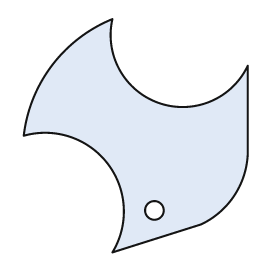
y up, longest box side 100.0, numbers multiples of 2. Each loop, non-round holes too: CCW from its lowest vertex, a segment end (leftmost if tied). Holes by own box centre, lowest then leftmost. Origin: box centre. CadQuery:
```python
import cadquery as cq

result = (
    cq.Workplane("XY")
    .moveTo(-10.0, -50.0)
    .lineTo(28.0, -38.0)
    .threePointArc((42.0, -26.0), (48.0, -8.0))
    .lineTo(48.0, 30.0)
    .threePointArc((10.0, 14.0), (-10.0, 50.0))
    .threePointArc((-36.0, 30.0), (-48.0, 0.0))
    .threePointArc((-12.0, -12.0), (-10.0, -50.0))
    .close()
    .moveTo(8.0, -32.0)
    .circle(4.0)
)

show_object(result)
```